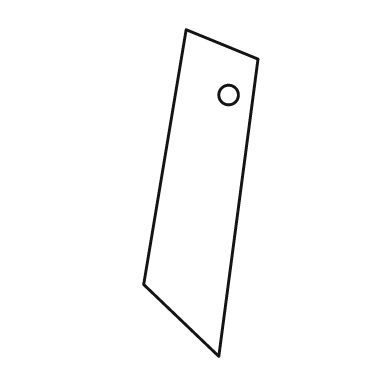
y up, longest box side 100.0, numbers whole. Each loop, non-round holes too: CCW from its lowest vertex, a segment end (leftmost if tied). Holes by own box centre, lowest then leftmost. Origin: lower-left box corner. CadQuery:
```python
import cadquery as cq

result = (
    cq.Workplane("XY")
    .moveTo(23.0, 0.0)
    .lineTo(35.0, 91.0)
    .lineTo(13.0, 100.0)
    .lineTo(0.0, 22.0)
    .close()
    .moveTo(26.0, 80.0)
    .circle(3.0)
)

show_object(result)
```